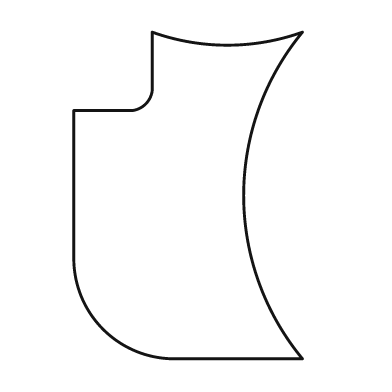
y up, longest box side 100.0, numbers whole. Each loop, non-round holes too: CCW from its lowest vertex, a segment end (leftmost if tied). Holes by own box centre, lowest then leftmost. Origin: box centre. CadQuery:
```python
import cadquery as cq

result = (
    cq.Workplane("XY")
    .moveTo(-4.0, -50.0)
    .lineTo(35.0, -50.0)
    .threePointArc((17.0, 0.0), (35.0, 50.0))
    .threePointArc((12.0, 46.0), (-11.0, 50.0))
    .lineTo(-11.0, 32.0)
    .threePointArc((-13.0, 28.0), (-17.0, 26.0))
    .lineTo(-35.0, 26.0)
    .lineTo(-35.0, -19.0)
    .threePointArc((-26.0, -41.0), (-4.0, -50.0))
    .close()
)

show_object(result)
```